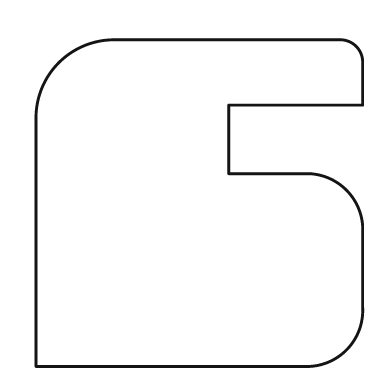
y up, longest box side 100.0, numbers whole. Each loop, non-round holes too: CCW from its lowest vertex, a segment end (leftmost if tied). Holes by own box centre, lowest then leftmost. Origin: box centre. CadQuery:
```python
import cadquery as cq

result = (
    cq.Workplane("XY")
    .moveTo(-50.0, -50.0)
    .lineTo(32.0, -50.0)
    .threePointArc((45.0, -45.0), (50.0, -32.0))
    .lineTo(50.0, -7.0)
    .threePointArc((45.0, 4.0), (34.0, 9.0))
    .lineTo(9.0, 9.0)
    .lineTo(9.0, 30.0)
    .lineTo(50.0, 30.0)
    .lineTo(50.0, 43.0)
    .threePointArc((48.0, 48.0), (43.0, 50.0))
    .lineTo(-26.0, 50.0)
    .threePointArc((-43.0, 43.0), (-50.0, 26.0))
    .close()
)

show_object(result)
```